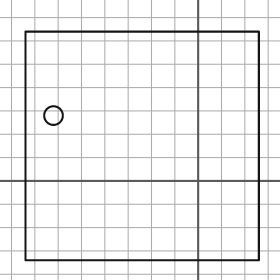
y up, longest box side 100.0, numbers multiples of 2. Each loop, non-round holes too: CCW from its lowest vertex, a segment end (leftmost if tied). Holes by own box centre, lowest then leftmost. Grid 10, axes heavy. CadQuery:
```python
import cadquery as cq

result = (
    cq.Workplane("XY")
    .moveTo(-74.0, -34.0)
    .lineTo(26.0, -34.0)
    .lineTo(26.0, 64.0)
    .lineTo(-74.0, 64.0)
    .close()
    .moveTo(-62.0, 28.0)
    .circle(4.0)
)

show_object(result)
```